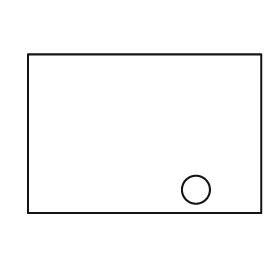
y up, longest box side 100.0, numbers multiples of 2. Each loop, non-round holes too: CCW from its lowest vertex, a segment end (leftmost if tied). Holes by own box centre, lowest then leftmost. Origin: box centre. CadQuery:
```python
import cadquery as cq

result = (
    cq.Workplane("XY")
    .moveTo(-50.0, -34.0)
    .lineTo(50.0, -34.0)
    .lineTo(50.0, 34.0)
    .lineTo(-50.0, 34.0)
    .close()
    .moveTo(22.0, -24.0)
    .circle(6.0)
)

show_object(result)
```